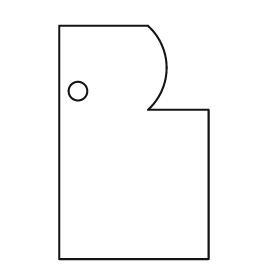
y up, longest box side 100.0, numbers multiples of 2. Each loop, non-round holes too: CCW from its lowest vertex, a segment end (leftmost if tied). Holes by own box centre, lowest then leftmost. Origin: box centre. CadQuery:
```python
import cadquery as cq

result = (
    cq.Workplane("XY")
    .moveTo(-32.0, -50.0)
    .lineTo(32.0, -50.0)
    .lineTo(32.0, 14.0)
    .lineTo(6.0, 14.0)
    .threePointArc((14.0, 32.0), (6.0, 50.0))
    .lineTo(-32.0, 50.0)
    .close()
    .moveTo(-24.0, 22.0)
    .circle(4.0)
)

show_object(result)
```